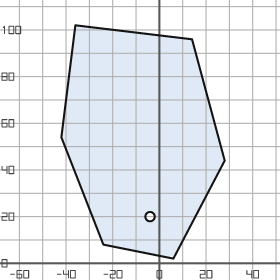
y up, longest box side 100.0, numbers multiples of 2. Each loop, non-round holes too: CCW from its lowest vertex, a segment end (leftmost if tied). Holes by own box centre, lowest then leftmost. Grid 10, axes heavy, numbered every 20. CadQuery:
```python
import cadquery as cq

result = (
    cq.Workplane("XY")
    .moveTo(6.0, 2.0)
    .lineTo(28.0, 44.0)
    .lineTo(14.0, 96.0)
    .lineTo(-36.0, 102.0)
    .lineTo(-42.0, 54.0)
    .lineTo(-24.0, 8.0)
    .close()
    .moveTo(-4.0, 20.0)
    .circle(2.0)
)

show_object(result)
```